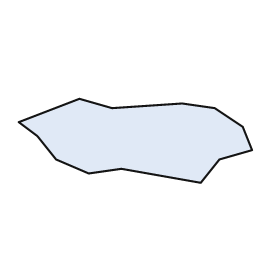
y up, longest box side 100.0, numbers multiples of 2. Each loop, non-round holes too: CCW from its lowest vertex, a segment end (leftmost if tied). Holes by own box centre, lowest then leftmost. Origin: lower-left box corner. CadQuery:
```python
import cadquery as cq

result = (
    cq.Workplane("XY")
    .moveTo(78.0, 0.0)
    .lineTo(86.0, 10.0)
    .lineTo(100.0, 14.0)
    .lineTo(96.0, 24.0)
    .lineTo(84.0, 32.0)
    .lineTo(70.0, 34.0)
    .lineTo(40.0, 32.0)
    .lineTo(26.0, 36.0)
    .lineTo(0.0, 26.0)
    .lineTo(8.0, 20.0)
    .lineTo(16.0, 10.0)
    .lineTo(30.0, 4.0)
    .lineTo(44.0, 6.0)
    .close()
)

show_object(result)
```